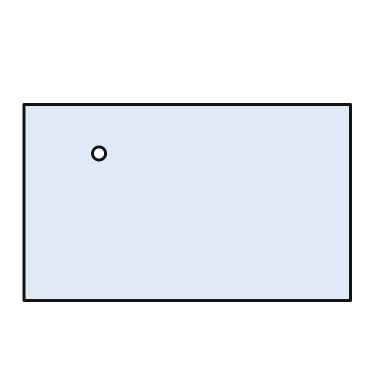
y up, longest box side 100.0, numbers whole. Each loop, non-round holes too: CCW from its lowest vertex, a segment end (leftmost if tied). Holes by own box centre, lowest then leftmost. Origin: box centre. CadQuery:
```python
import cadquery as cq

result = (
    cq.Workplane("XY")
    .moveTo(-50.0, -30.0)
    .lineTo(50.0, -30.0)
    .lineTo(50.0, 30.0)
    .lineTo(-50.0, 30.0)
    .close()
    .moveTo(-27.0, 15.0)
    .circle(2.0)
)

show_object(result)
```